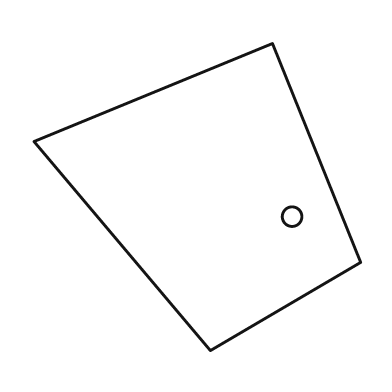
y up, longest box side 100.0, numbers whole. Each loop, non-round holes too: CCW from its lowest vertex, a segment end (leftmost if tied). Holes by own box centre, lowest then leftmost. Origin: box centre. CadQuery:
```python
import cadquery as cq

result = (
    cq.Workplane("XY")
    .moveTo(4.0, -47.0)
    .lineTo(50.0, -20.0)
    .lineTo(23.0, 47.0)
    .lineTo(-50.0, 17.0)
    .close()
    .moveTo(29.0, -6.0)
    .circle(3.0)
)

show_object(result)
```